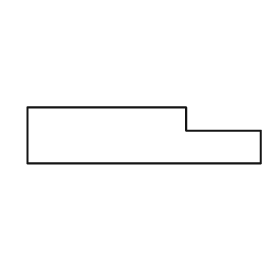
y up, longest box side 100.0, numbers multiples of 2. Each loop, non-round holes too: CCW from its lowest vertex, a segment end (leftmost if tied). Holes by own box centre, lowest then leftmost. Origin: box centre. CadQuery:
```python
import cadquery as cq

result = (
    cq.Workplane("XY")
    .moveTo(-50.0, -12.0)
    .lineTo(50.0, -12.0)
    .lineTo(50.0, 2.0)
    .lineTo(18.0, 2.0)
    .lineTo(18.0, 12.0)
    .lineTo(-50.0, 12.0)
    .close()
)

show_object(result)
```